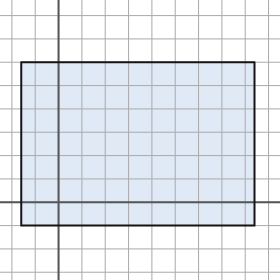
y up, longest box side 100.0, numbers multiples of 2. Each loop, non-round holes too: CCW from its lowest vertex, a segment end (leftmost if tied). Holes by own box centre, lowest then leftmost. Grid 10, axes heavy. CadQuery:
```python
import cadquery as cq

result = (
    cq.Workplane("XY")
    .moveTo(-16.0, -10.0)
    .lineTo(84.0, -10.0)
    .lineTo(84.0, 60.0)
    .lineTo(-16.0, 60.0)
    .close()
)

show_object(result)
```